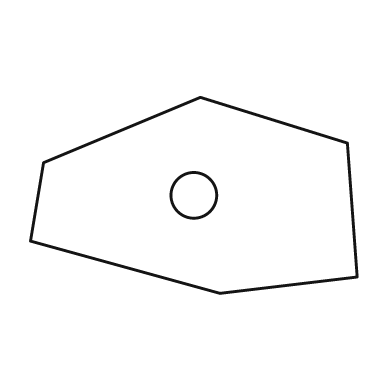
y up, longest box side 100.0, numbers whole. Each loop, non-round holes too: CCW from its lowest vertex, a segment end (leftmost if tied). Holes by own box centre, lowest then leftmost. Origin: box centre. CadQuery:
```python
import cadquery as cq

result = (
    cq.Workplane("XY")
    .moveTo(8.0, -30.0)
    .lineTo(50.0, -25.0)
    .lineTo(47.0, 16.0)
    .lineTo(2.0, 30.0)
    .lineTo(-46.0, 10.0)
    .lineTo(-50.0, -14.0)
    .close()
    .moveTo(0.0, 0.0)
    .circle(7.0)
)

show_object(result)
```